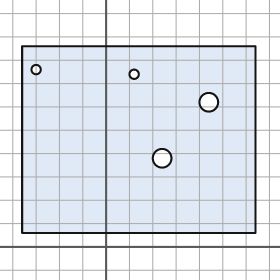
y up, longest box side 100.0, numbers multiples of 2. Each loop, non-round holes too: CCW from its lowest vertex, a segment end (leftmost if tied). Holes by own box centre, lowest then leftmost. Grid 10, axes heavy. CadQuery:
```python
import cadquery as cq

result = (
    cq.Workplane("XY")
    .moveTo(-36.0, 6.0)
    .lineTo(64.0, 6.0)
    .lineTo(64.0, 86.0)
    .lineTo(-36.0, 86.0)
    .close()
    .moveTo(24.0, 38.0)
    .circle(4.0)
    .moveTo(44.0, 62.0)
    .circle(4.0)
    .moveTo(12.0, 74.0)
    .circle(2.0)
    .moveTo(-30.0, 76.0)
    .circle(2.0)
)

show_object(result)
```